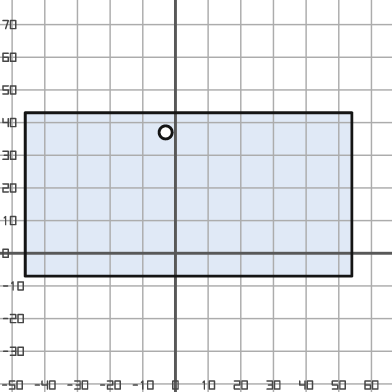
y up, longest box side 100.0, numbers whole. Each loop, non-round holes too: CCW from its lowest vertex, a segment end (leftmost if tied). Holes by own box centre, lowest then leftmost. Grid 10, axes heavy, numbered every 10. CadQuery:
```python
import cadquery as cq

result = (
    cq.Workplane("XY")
    .moveTo(-46.0, -7.0)
    .lineTo(54.0, -7.0)
    .lineTo(54.0, 43.0)
    .lineTo(-46.0, 43.0)
    .close()
    .moveTo(-3.0, 37.0)
    .circle(2.0)
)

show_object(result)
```